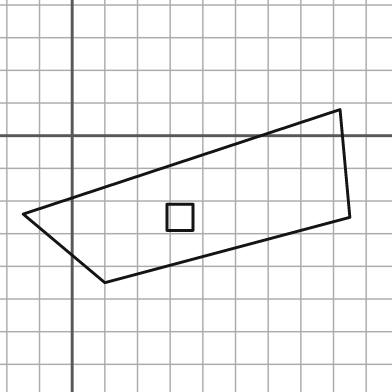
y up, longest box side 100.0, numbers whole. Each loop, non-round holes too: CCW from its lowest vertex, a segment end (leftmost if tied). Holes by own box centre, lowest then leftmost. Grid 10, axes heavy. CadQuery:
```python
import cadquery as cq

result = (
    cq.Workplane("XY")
    .moveTo(10.0, -45.0)
    .lineTo(85.0, -25.0)
    .lineTo(82.0, 8.0)
    .lineTo(-15.0, -24.0)
    .close()
    .moveTo(29.0, -29.0)
    .lineTo(37.0, -29.0)
    .lineTo(37.0, -21.0)
    .lineTo(29.0, -21.0)
    .close()
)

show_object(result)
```